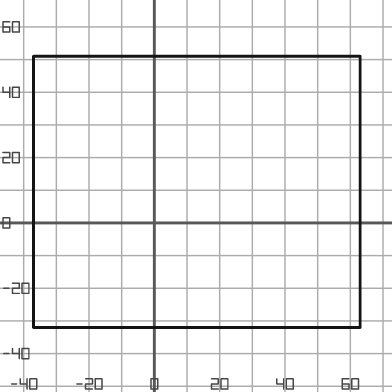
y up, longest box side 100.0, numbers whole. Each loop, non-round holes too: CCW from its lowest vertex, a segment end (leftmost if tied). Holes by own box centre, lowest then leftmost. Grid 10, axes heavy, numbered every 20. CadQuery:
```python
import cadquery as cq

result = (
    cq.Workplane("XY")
    .moveTo(-37.0, -32.0)
    .lineTo(63.0, -32.0)
    .lineTo(63.0, 51.0)
    .lineTo(-37.0, 51.0)
    .close()
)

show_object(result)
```